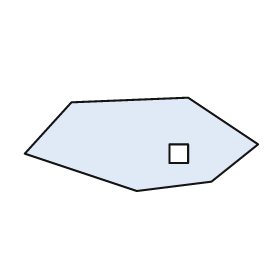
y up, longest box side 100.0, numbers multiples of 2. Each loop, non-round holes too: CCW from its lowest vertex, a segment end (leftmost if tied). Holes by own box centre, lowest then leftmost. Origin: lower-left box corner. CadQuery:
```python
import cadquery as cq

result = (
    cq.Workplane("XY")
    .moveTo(48.0, 0.0)
    .lineTo(80.0, 4.0)
    .lineTo(100.0, 20.0)
    .lineTo(70.0, 40.0)
    .lineTo(20.0, 38.0)
    .lineTo(0.0, 16.0)
    .close()
    .moveTo(62.0, 12.0)
    .lineTo(70.0, 12.0)
    .lineTo(70.0, 20.0)
    .lineTo(62.0, 20.0)
    .close()
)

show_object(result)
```